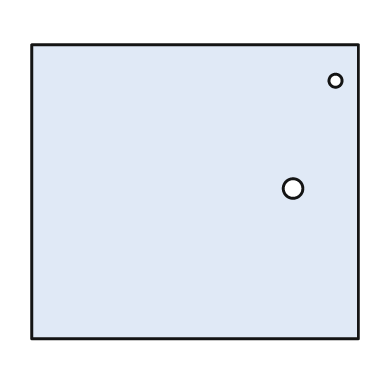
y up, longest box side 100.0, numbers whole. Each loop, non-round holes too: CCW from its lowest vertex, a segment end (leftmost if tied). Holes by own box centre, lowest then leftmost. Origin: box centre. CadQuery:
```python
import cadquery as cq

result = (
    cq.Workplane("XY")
    .moveTo(-50.0, -45.0)
    .lineTo(50.0, -45.0)
    .lineTo(50.0, 45.0)
    .lineTo(-50.0, 45.0)
    .close()
    .moveTo(30.0, 1.0)
    .circle(3.0)
    .moveTo(43.0, 34.0)
    .circle(2.0)
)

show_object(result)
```